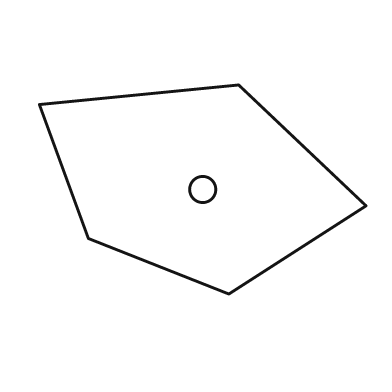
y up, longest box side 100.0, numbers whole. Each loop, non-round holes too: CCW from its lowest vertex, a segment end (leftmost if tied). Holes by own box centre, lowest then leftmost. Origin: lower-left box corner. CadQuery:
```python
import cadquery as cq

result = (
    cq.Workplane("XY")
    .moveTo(58.0, 0.0)
    .lineTo(100.0, 27.0)
    .lineTo(61.0, 64.0)
    .lineTo(0.0, 58.0)
    .lineTo(15.0, 17.0)
    .close()
    .moveTo(50.0, 32.0)
    .circle(4.0)
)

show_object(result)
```